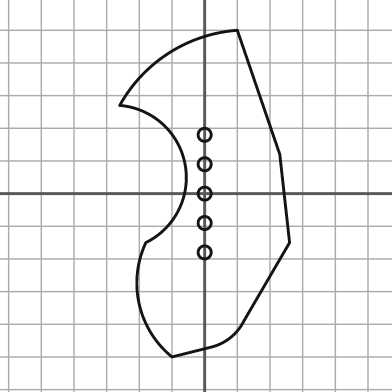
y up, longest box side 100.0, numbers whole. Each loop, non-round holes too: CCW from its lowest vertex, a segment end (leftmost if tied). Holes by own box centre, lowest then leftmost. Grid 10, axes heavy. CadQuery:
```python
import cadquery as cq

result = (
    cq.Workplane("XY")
    .moveTo(-10.0, -50.0)
    .lineTo(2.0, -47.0)
    .threePointArc((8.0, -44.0), (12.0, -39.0))
    .lineTo(26.0, -15.0)
    .lineTo(23.0, 12.0)
    .lineTo(10.0, 50.0)
    .threePointArc((-11.0, 43.0), (-26.0, 27.0))
    .threePointArc((-6.0, 9.0), (-18.0, -15.0))
    .threePointArc((-20.0, -34.0), (-10.0, -50.0))
    .close()
    .moveTo(0.0, -18.0)
    .circle(2.0)
    .moveTo(0.0, -9.0)
    .circle(2.0)
    .moveTo(0.0, 0.0)
    .circle(2.0)
    .moveTo(0.0, 9.0)
    .circle(2.0)
    .moveTo(0.0, 18.0)
    .circle(2.0)
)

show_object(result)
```